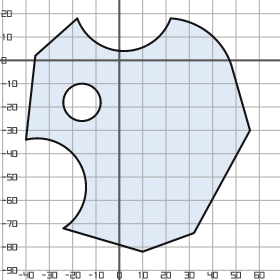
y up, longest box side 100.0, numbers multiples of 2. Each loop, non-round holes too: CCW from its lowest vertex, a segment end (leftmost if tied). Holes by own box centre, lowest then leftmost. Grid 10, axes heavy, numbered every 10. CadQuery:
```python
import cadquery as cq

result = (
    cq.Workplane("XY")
    .moveTo(10.0, -82.0)
    .lineTo(32.0, -74.0)
    .lineTo(56.0, -30.0)
    .lineTo(48.0, -2.0)
    .threePointArc((38.0, 12.0), (22.0, 18.0))
    .threePointArc((2.0, 4.0), (-18.0, 18.0))
    .lineTo(-36.0, 2.0)
    .lineTo(-40.0, -34.0)
    .threePointArc((-16.0, -46.0), (-24.0, -72.0))
    .close()
    .moveTo(-16.0, -18.0)
    .circle(8.0)
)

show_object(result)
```